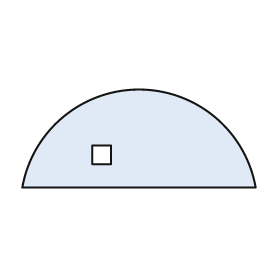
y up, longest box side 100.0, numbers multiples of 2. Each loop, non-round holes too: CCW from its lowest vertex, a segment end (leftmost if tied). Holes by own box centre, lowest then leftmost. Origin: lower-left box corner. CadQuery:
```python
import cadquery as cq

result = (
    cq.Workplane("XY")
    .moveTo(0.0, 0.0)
    .lineTo(100.0, 0.0)
    .threePointArc((50.0, 42.0), (0.0, 0.0))
    .close()
    .moveTo(30.0, 10.0)
    .lineTo(38.0, 10.0)
    .lineTo(38.0, 18.0)
    .lineTo(30.0, 18.0)
    .close()
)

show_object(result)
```